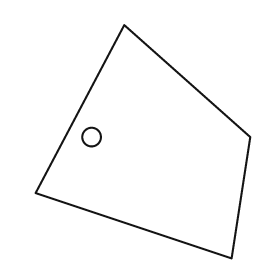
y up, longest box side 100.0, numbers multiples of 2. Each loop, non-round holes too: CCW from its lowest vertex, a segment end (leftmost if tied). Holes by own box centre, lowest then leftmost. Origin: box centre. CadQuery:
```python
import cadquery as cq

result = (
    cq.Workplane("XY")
    .moveTo(38.0, -50.0)
    .lineTo(46.0, 2.0)
    .lineTo(-8.0, 50.0)
    .lineTo(-46.0, -22.0)
    .close()
    .moveTo(-22.0, 2.0)
    .circle(4.0)
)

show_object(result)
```